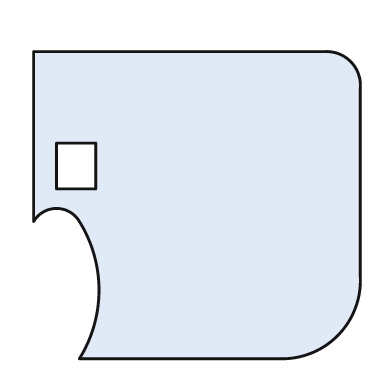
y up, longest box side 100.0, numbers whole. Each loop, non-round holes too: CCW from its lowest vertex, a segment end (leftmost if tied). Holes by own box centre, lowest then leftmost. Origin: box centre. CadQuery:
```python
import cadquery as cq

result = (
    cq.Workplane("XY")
    .moveTo(-36.0, -47.0)
    .lineTo(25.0, -47.0)
    .threePointArc((43.0, -40.0), (50.0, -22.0))
    .lineTo(50.0, 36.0)
    .threePointArc((47.0, 44.0), (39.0, 47.0))
    .lineTo(-50.0, 47.0)
    .lineTo(-50.0, -5.0)
    .threePointArc((-43.0, -1.0), (-36.0, -5.0))
    .threePointArc((-30.0, -26.0), (-36.0, -47.0))
    .close()
    .moveTo(-43.0, 5.0)
    .lineTo(-31.0, 5.0)
    .lineTo(-31.0, 19.0)
    .lineTo(-43.0, 19.0)
    .close()
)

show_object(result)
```